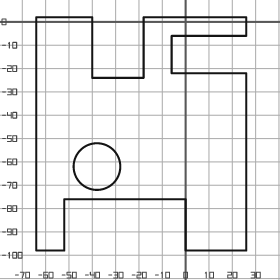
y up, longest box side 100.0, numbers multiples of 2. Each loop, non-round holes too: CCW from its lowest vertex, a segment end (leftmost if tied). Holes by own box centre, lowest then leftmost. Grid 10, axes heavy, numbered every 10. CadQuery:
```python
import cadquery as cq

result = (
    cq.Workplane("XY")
    .moveTo(-64.0, -98.0)
    .lineTo(-52.0, -98.0)
    .lineTo(-52.0, -76.0)
    .lineTo(0.0, -76.0)
    .lineTo(0.0, -98.0)
    .lineTo(26.0, -98.0)
    .lineTo(26.0, -22.0)
    .lineTo(-6.0, -22.0)
    .lineTo(-6.0, -6.0)
    .lineTo(26.0, -6.0)
    .lineTo(26.0, 2.0)
    .lineTo(-18.0, 2.0)
    .lineTo(-18.0, -24.0)
    .lineTo(-40.0, -24.0)
    .lineTo(-40.0, 2.0)
    .lineTo(-64.0, 2.0)
    .close()
    .moveTo(-38.0, -62.0)
    .circle(10.0)
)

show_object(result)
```